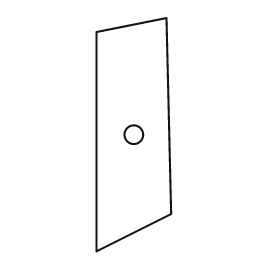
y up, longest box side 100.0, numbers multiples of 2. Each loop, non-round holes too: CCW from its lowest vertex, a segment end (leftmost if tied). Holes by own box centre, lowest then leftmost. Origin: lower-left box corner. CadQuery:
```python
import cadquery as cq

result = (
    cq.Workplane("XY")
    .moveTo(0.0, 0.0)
    .lineTo(32.0, 16.0)
    .lineTo(30.0, 100.0)
    .lineTo(0.0, 94.0)
    .close()
    .moveTo(16.0, 50.0)
    .circle(4.0)
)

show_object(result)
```